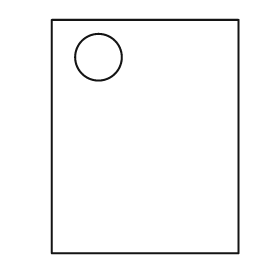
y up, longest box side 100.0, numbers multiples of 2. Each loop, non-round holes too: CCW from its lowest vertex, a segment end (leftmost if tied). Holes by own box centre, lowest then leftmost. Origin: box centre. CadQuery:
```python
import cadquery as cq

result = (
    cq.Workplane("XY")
    .moveTo(-40.0, -50.0)
    .lineTo(40.0, -50.0)
    .lineTo(40.0, 50.0)
    .lineTo(-40.0, 50.0)
    .close()
    .moveTo(-20.0, 34.0)
    .circle(10.0)
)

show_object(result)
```